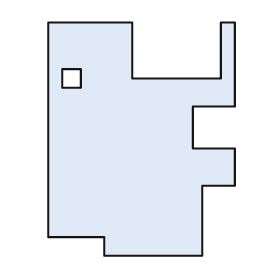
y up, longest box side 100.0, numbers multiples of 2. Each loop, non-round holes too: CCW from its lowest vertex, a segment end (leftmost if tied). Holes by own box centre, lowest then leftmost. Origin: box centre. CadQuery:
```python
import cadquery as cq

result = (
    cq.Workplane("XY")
    .moveTo(-16.0, -50.0)
    .lineTo(26.0, -50.0)
    .lineTo(26.0, -20.0)
    .lineTo(40.0, -20.0)
    .lineTo(40.0, -4.0)
    .lineTo(22.0, -4.0)
    .lineTo(22.0, 14.0)
    .lineTo(40.0, 14.0)
    .lineTo(40.0, 50.0)
    .lineTo(34.0, 50.0)
    .lineTo(34.0, 26.0)
    .lineTo(-4.0, 26.0)
    .lineTo(-4.0, 50.0)
    .lineTo(-40.0, 50.0)
    .lineTo(-40.0, -42.0)
    .lineTo(-16.0, -42.0)
    .close()
    .moveTo(-34.0, 22.0)
    .lineTo(-26.0, 22.0)
    .lineTo(-26.0, 30.0)
    .lineTo(-34.0, 30.0)
    .close()
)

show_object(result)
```